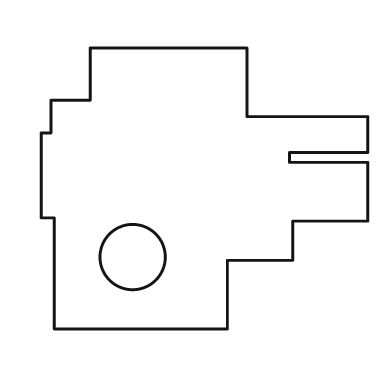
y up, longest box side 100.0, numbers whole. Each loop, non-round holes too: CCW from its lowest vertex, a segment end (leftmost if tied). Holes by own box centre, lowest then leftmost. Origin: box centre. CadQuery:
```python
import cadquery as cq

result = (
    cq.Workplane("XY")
    .moveTo(-46.0, -43.0)
    .lineTo(7.0, -43.0)
    .lineTo(7.0, -22.0)
    .lineTo(27.0, -22.0)
    .lineTo(27.0, -10.0)
    .lineTo(50.0, -10.0)
    .lineTo(50.0, 8.0)
    .lineTo(26.0, 8.0)
    .lineTo(26.0, 11.0)
    .lineTo(50.0, 11.0)
    .lineTo(50.0, 22.0)
    .lineTo(13.0, 22.0)
    .lineTo(13.0, 43.0)
    .lineTo(-35.0, 43.0)
    .lineTo(-35.0, 27.0)
    .lineTo(-47.0, 27.0)
    .lineTo(-47.0, 17.0)
    .lineTo(-50.0, 17.0)
    .lineTo(-50.0, -9.0)
    .lineTo(-46.0, -9.0)
    .close()
    .moveTo(-22.0, -21.0)
    .circle(10.0)
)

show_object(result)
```